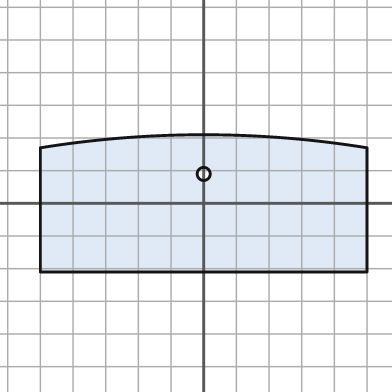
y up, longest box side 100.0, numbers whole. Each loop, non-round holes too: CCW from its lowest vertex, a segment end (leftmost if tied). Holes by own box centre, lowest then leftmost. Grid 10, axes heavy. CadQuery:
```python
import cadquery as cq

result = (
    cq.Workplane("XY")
    .moveTo(-50.0, -21.0)
    .lineTo(50.0, -21.0)
    .lineTo(50.0, 17.0)
    .threePointArc((0.0, 21.0), (-50.0, 17.0))
    .close()
    .moveTo(0.0, 9.0)
    .circle(2.0)
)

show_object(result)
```